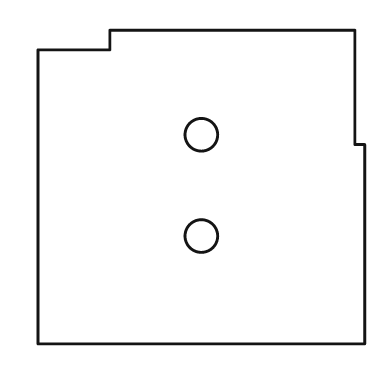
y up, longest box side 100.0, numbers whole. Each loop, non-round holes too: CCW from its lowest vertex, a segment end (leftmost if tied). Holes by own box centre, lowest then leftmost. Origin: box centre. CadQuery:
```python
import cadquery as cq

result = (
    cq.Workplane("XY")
    .moveTo(-50.0, -48.0)
    .lineTo(50.0, -48.0)
    .lineTo(50.0, 13.0)
    .lineTo(47.0, 13.0)
    .lineTo(47.0, 48.0)
    .lineTo(-28.0, 48.0)
    .lineTo(-28.0, 42.0)
    .lineTo(-50.0, 42.0)
    .close()
    .moveTo(0.0, -15.0)
    .circle(5.0)
    .moveTo(0.0, 16.0)
    .circle(5.0)
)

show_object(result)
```